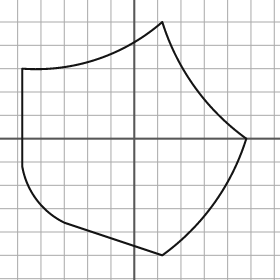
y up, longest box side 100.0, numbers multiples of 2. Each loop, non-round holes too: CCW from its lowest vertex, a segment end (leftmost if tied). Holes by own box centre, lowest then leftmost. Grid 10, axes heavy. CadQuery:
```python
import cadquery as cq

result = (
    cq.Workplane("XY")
    .moveTo(12.0, -50.0)
    .threePointArc((34.0, -28.0), (48.0, 0.0))
    .threePointArc((26.0, 22.0), (12.0, 50.0))
    .threePointArc((-16.0, 34.0), (-48.0, 30.0))
    .lineTo(-48.0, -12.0)
    .threePointArc((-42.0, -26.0), (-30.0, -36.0))
    .close()
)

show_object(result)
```